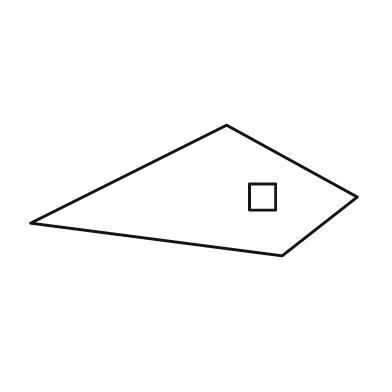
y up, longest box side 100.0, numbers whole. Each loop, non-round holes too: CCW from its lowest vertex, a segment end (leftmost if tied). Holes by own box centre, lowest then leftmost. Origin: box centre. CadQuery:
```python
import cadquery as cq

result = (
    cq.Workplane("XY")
    .moveTo(27.0, -20.0)
    .lineTo(50.0, -2.0)
    .lineTo(10.0, 20.0)
    .lineTo(-50.0, -10.0)
    .close()
    .moveTo(17.0, -6.0)
    .lineTo(25.0, -6.0)
    .lineTo(25.0, 2.0)
    .lineTo(17.0, 2.0)
    .close()
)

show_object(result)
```